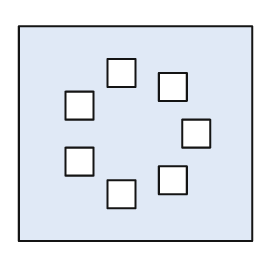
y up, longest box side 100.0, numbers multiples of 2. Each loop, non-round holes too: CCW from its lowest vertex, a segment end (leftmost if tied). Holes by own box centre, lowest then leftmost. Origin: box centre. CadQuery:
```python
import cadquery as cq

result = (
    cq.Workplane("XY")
    .moveTo(-50.0, -46.0)
    .lineTo(50.0, -46.0)
    .lineTo(50.0, 46.0)
    .lineTo(-50.0, 46.0)
    .close()
    .moveTo(-12.0, -32.0)
    .lineTo(0.0, -32.0)
    .lineTo(0.0, -20.0)
    .lineTo(-12.0, -20.0)
    .close()
    .moveTo(10.0, -26.0)
    .lineTo(22.0, -26.0)
    .lineTo(22.0, -14.0)
    .lineTo(10.0, -14.0)
    .close()
    .moveTo(-30.0, -18.0)
    .lineTo(-18.0, -18.0)
    .lineTo(-18.0, -6.0)
    .lineTo(-30.0, -6.0)
    .close()
    .moveTo(20.0, -6.0)
    .lineTo(32.0, -6.0)
    .lineTo(32.0, 6.0)
    .lineTo(20.0, 6.0)
    .close()
    .moveTo(-30.0, 6.0)
    .lineTo(-18.0, 6.0)
    .lineTo(-18.0, 18.0)
    .lineTo(-30.0, 18.0)
    .close()
    .moveTo(10.0, 14.0)
    .lineTo(22.0, 14.0)
    .lineTo(22.0, 26.0)
    .lineTo(10.0, 26.0)
    .close()
    .moveTo(-12.0, 20.0)
    .lineTo(0.0, 20.0)
    .lineTo(0.0, 32.0)
    .lineTo(-12.0, 32.0)
    .close()
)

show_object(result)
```